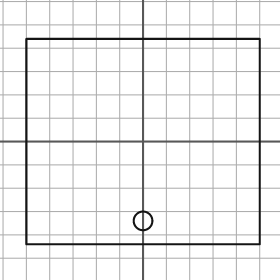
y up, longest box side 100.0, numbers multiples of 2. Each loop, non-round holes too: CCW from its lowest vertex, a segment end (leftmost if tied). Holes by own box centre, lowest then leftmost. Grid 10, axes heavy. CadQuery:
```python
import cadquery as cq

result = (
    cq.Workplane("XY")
    .moveTo(-50.0, -44.0)
    .lineTo(50.0, -44.0)
    .lineTo(50.0, 44.0)
    .lineTo(-50.0, 44.0)
    .close()
    .moveTo(0.0, -34.0)
    .circle(4.0)
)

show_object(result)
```